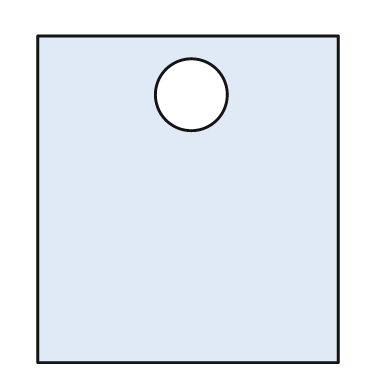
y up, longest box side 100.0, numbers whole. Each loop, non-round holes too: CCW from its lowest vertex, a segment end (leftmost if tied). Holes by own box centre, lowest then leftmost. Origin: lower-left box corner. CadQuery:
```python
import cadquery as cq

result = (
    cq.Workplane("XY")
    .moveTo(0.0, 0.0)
    .lineTo(92.0, 0.0)
    .lineTo(92.0, 100.0)
    .lineTo(0.0, 100.0)
    .close()
    .moveTo(47.0, 82.0)
    .circle(11.0)
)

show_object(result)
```